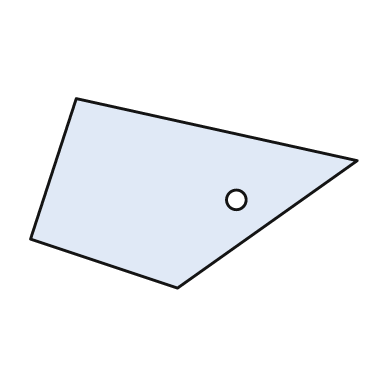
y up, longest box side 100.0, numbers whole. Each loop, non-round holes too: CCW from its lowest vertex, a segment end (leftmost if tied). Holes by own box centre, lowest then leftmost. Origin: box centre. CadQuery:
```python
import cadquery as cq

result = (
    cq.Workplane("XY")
    .moveTo(-5.0, -29.0)
    .lineTo(50.0, 10.0)
    .lineTo(-36.0, 29.0)
    .lineTo(-50.0, -14.0)
    .close()
    .moveTo(13.0, -2.0)
    .circle(3.0)
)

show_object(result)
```